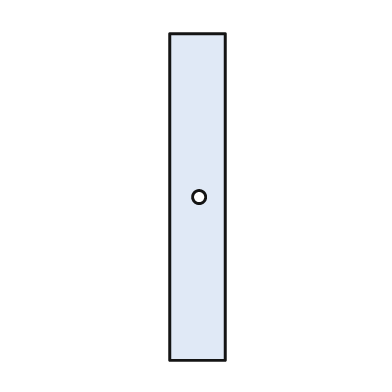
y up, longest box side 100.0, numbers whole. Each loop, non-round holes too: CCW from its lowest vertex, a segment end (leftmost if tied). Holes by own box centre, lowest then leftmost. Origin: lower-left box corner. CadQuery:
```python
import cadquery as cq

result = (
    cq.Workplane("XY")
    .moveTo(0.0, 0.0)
    .lineTo(17.0, 0.0)
    .lineTo(17.0, 100.0)
    .lineTo(0.0, 100.0)
    .close()
    .moveTo(9.0, 50.0)
    .circle(2.0)
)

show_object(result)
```